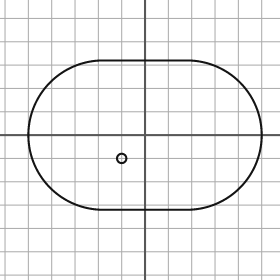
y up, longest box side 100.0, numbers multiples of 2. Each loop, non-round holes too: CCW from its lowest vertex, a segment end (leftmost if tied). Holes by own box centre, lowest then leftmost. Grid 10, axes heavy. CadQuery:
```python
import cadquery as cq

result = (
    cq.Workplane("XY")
    .moveTo(-18.0, -32.0)
    .lineTo(18.0, -32.0)
    .threePointArc((50.0, 0.0), (18.0, 32.0))
    .lineTo(-18.0, 32.0)
    .threePointArc((-50.0, 0.0), (-18.0, -32.0))
    .close()
    .moveTo(-10.0, -10.0)
    .circle(2.0)
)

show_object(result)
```